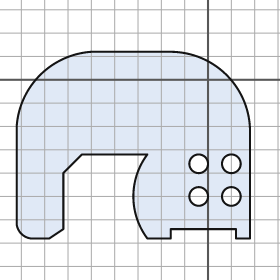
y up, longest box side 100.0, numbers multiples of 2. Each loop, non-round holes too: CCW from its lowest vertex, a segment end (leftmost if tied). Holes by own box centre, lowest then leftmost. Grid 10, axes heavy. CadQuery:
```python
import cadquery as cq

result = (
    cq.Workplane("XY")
    .moveTo(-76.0, -68.0)
    .lineTo(-68.0, -68.0)
    .lineTo(-62.0, -64.0)
    .lineTo(-62.0, -40.0)
    .lineTo(-54.0, -32.0)
    .lineTo(-26.0, -32.0)
    .threePointArc((-32.0, -50.0), (-26.0, -68.0))
    .lineTo(-16.0, -68.0)
    .lineTo(-16.0, -64.0)
    .lineTo(12.0, -64.0)
    .lineTo(12.0, -68.0)
    .lineTo(18.0, -68.0)
    .lineTo(18.0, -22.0)
    .threePointArc((8.0, 2.0), (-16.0, 12.0))
    .lineTo(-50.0, 12.0)
    .threePointArc((-72.0, 2.0), (-82.0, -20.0))
    .lineTo(-82.0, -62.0)
    .threePointArc((-80.0, -66.0), (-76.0, -68.0))
    .close()
    .moveTo(-4.0, -50.0)
    .circle(4.0)
    .moveTo(10.0, -50.0)
    .circle(4.0)
    .moveTo(-4.0, -36.0)
    .circle(4.0)
    .moveTo(10.0, -36.0)
    .circle(4.0)
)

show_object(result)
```